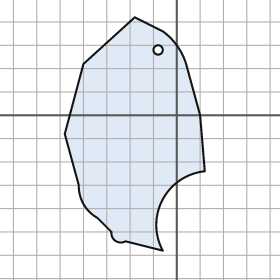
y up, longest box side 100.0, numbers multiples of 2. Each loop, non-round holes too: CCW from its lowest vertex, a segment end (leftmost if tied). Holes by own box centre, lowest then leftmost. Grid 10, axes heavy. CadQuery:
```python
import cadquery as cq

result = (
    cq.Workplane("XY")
    .moveTo(-6.0, -58.0)
    .threePointArc((-6.0, -36.0), (12.0, -24.0))
    .lineTo(10.0, 0.0)
    .lineTo(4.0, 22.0)
    .threePointArc((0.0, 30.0), (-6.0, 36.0))
    .lineTo(-18.0, 42.0)
    .lineTo(-40.0, 22.0)
    .lineTo(-48.0, -8.0)
    .lineTo(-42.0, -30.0)
    .threePointArc((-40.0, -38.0), (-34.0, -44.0))
    .lineTo(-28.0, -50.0)
    .threePointArc((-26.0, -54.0), (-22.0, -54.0))
    .close()
    .moveTo(-8.0, 28.0)
    .circle(2.0)
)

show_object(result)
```